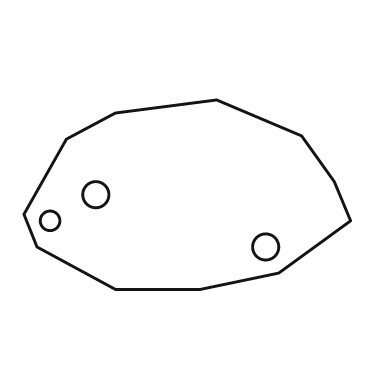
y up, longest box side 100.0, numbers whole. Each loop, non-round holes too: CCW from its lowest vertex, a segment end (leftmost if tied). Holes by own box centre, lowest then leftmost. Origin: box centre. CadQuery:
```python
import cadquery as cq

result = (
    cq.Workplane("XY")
    .moveTo(-22.0, -29.0)
    .lineTo(4.0, -29.0)
    .lineTo(28.0, -24.0)
    .lineTo(50.0, -8.0)
    .lineTo(45.0, 4.0)
    .lineTo(35.0, 18.0)
    .lineTo(9.0, 29.0)
    .lineTo(-22.0, 25.0)
    .lineTo(-37.0, 17.0)
    .lineTo(-50.0, -6.0)
    .lineTo(-46.0, -16.0)
    .close()
    .moveTo(24.0, -16.0)
    .circle(4.0)
    .moveTo(-42.0, -8.0)
    .circle(3.0)
    .moveTo(-28.0, 0.0)
    .circle(4.0)
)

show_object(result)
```